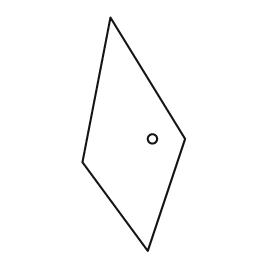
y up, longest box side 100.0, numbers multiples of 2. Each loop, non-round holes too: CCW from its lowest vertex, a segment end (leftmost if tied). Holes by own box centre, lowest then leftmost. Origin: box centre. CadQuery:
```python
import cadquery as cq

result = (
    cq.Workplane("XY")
    .moveTo(6.0, -50.0)
    .lineTo(22.0, -2.0)
    .lineTo(-10.0, 50.0)
    .lineTo(-22.0, -12.0)
    .close()
    .moveTo(8.0, -2.0)
    .circle(2.0)
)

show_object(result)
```